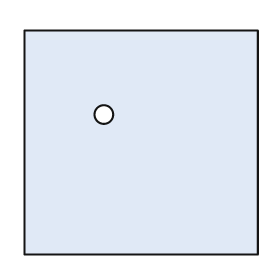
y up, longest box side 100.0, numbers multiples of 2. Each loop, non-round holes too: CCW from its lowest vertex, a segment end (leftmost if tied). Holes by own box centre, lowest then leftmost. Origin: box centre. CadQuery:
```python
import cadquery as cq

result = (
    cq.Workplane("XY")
    .moveTo(-50.0, -48.0)
    .lineTo(50.0, -48.0)
    .lineTo(50.0, 48.0)
    .lineTo(-50.0, 48.0)
    .close()
    .moveTo(-16.0, 12.0)
    .circle(4.0)
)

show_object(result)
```